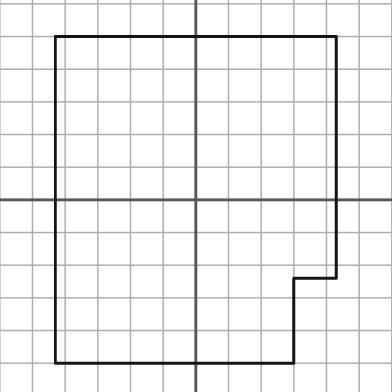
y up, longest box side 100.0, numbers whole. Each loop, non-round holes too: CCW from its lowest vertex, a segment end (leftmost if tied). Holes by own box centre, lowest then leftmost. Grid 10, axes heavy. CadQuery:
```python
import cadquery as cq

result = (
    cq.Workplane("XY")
    .moveTo(-43.0, -50.0)
    .lineTo(30.0, -50.0)
    .lineTo(30.0, -24.0)
    .lineTo(43.0, -24.0)
    .lineTo(43.0, 50.0)
    .lineTo(-43.0, 50.0)
    .close()
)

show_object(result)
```